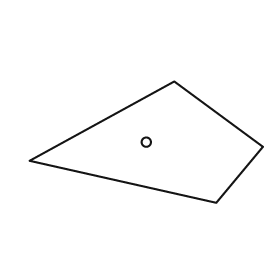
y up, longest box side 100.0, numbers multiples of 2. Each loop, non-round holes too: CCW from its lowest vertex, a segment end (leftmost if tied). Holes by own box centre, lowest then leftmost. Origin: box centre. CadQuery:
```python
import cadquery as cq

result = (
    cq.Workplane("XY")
    .moveTo(30.0, -26.0)
    .lineTo(50.0, -2.0)
    .lineTo(12.0, 26.0)
    .lineTo(-50.0, -8.0)
    .close()
    .moveTo(0.0, 0.0)
    .circle(2.0)
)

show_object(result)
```